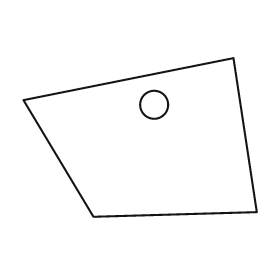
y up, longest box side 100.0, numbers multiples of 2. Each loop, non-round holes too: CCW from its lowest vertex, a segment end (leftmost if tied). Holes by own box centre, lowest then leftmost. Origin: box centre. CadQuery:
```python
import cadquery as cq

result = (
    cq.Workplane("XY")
    .moveTo(-20.0, -34.0)
    .lineTo(50.0, -32.0)
    .lineTo(40.0, 34.0)
    .lineTo(-50.0, 16.0)
    .close()
    .moveTo(6.0, 14.0)
    .circle(6.0)
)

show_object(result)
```